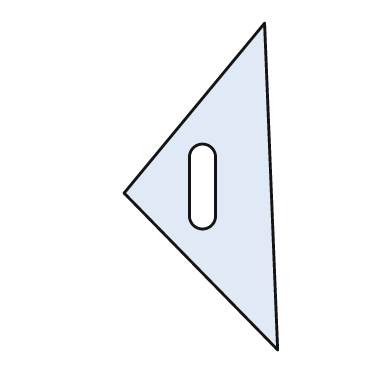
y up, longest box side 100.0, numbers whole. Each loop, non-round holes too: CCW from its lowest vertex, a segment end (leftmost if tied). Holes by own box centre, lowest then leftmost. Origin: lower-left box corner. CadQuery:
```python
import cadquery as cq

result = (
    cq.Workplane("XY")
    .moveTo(47.0, 0.0)
    .lineTo(43.0, 100.0)
    .lineTo(0.0, 48.0)
    .close()
    .moveTo(20.0, 41.0)
    .threePointArc((24.0, 37.0), (28.0, 41.0))
    .lineTo(28.0, 59.0)
    .threePointArc((24.0, 63.0), (20.0, 59.0))
    .close()
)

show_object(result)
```